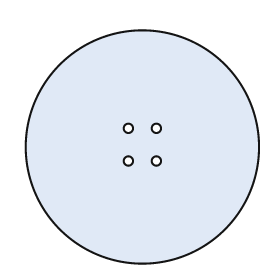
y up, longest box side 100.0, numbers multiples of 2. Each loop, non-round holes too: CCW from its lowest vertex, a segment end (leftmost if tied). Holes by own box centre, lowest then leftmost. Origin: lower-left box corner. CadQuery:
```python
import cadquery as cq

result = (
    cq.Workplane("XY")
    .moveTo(50.0, 50.0)
    .circle(50.0)
    .moveTo(44.0, 44.0)
    .circle(2.0)
    .moveTo(56.0, 44.0)
    .circle(2.0)
    .moveTo(44.0, 58.0)
    .circle(2.0)
    .moveTo(56.0, 58.0)
    .circle(2.0)
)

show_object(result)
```